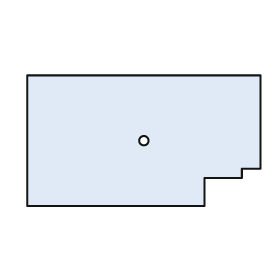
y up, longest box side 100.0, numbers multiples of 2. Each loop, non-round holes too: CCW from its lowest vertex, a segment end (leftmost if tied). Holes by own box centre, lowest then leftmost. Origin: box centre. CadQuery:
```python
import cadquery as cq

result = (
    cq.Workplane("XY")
    .moveTo(-50.0, -28.0)
    .lineTo(26.0, -28.0)
    .lineTo(26.0, -16.0)
    .lineTo(42.0, -16.0)
    .lineTo(42.0, -12.0)
    .lineTo(50.0, -12.0)
    .lineTo(50.0, 28.0)
    .lineTo(-50.0, 28.0)
    .close()
    .moveTo(0.0, 0.0)
    .circle(2.0)
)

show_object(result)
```